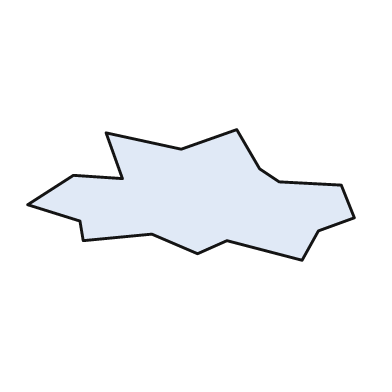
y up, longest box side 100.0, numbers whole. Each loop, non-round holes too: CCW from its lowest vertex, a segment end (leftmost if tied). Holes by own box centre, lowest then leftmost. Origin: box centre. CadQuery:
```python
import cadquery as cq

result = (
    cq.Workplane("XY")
    .moveTo(34.0, -20.0)
    .lineTo(39.0, -11.0)
    .lineTo(50.0, -7.0)
    .lineTo(46.0, 3.0)
    .lineTo(27.0, 4.0)
    .lineTo(21.0, 8.0)
    .lineTo(14.0, 20.0)
    .lineTo(-3.0, 14.0)
    .lineTo(-26.0, 19.0)
    .lineTo(-21.0, 5.0)
    .lineTo(-36.0, 6.0)
    .lineTo(-50.0, -3.0)
    .lineTo(-34.0, -8.0)
    .lineTo(-33.0, -14.0)
    .lineTo(-12.0, -12.0)
    .lineTo(2.0, -18.0)
    .lineTo(11.0, -14.0)
    .close()
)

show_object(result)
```